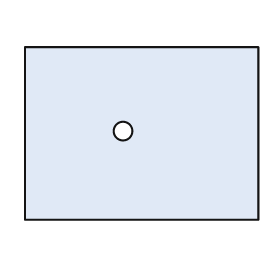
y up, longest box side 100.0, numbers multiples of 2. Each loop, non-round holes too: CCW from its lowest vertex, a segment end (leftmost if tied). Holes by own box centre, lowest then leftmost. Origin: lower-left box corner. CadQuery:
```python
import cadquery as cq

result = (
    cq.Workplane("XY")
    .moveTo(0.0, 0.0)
    .lineTo(100.0, 0.0)
    .lineTo(100.0, 74.0)
    .lineTo(0.0, 74.0)
    .close()
    .moveTo(42.0, 38.0)
    .circle(4.0)
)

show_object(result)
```